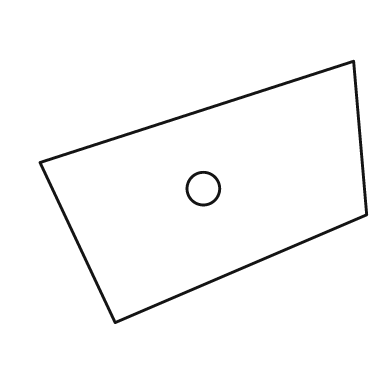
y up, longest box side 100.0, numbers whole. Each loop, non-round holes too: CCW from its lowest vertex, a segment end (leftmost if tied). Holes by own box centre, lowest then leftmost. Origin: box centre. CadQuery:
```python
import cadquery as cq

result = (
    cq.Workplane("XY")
    .moveTo(-27.0, -40.0)
    .lineTo(50.0, -7.0)
    .lineTo(46.0, 40.0)
    .lineTo(-50.0, 9.0)
    .close()
    .moveTo(0.0, 1.0)
    .circle(5.0)
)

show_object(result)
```